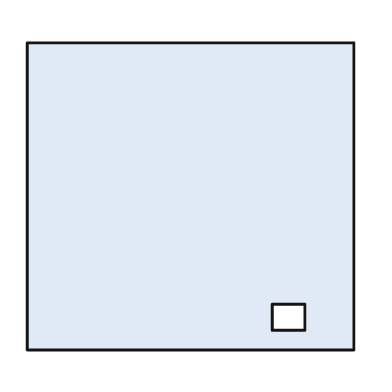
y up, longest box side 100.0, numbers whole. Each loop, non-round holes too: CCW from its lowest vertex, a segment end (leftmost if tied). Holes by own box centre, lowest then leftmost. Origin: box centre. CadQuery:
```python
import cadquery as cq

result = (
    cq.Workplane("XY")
    .moveTo(-50.0, -47.0)
    .lineTo(50.0, -47.0)
    .lineTo(50.0, 47.0)
    .lineTo(-50.0, 47.0)
    .close()
    .moveTo(25.0, -41.0)
    .lineTo(35.0, -41.0)
    .lineTo(35.0, -33.0)
    .lineTo(25.0, -33.0)
    .close()
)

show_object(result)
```